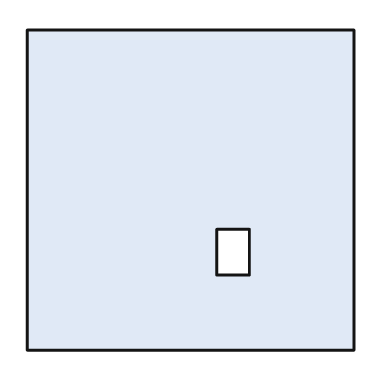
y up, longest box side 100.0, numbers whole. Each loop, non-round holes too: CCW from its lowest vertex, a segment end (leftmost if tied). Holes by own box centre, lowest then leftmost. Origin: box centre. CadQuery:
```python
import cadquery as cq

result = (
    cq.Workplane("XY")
    .moveTo(-50.0, -49.0)
    .lineTo(50.0, -49.0)
    .lineTo(50.0, 49.0)
    .lineTo(-50.0, 49.0)
    .close()
    .moveTo(8.0, -26.0)
    .lineTo(18.0, -26.0)
    .lineTo(18.0, -12.0)
    .lineTo(8.0, -12.0)
    .close()
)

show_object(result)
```